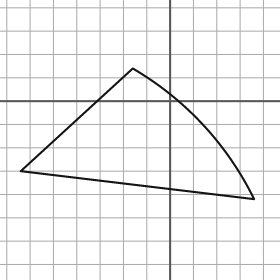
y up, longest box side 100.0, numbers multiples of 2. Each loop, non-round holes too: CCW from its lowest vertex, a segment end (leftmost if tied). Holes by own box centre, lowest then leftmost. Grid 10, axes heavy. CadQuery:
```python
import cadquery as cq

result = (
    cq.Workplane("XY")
    .moveTo(36.0, -42.0)
    .threePointArc((14.0, -10.0), (-16.0, 14.0))
    .lineTo(-64.0, -30.0)
    .close()
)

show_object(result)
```